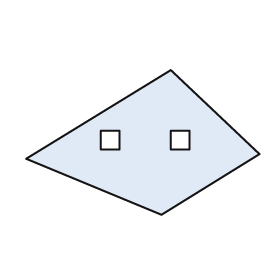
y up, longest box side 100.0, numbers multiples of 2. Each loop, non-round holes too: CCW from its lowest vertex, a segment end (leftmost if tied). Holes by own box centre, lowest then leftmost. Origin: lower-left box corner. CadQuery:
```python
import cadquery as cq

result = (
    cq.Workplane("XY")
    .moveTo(58.0, 0.0)
    .lineTo(100.0, 26.0)
    .lineTo(62.0, 62.0)
    .lineTo(0.0, 24.0)
    .close()
    .moveTo(32.0, 28.0)
    .lineTo(40.0, 28.0)
    .lineTo(40.0, 36.0)
    .lineTo(32.0, 36.0)
    .close()
    .moveTo(62.0, 28.0)
    .lineTo(70.0, 28.0)
    .lineTo(70.0, 36.0)
    .lineTo(62.0, 36.0)
    .close()
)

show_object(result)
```